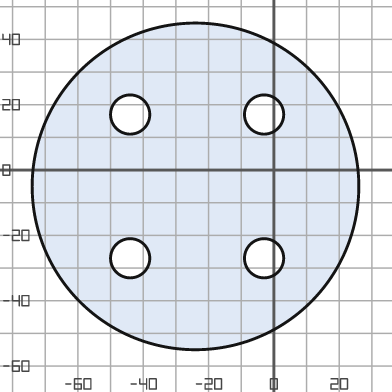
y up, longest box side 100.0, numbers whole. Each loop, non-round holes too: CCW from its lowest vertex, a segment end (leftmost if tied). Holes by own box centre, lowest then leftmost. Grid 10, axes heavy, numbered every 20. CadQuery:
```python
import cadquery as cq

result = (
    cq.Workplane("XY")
    .moveTo(-24.0, -5.0)
    .circle(50.0)
    .moveTo(-44.0, -27.0)
    .circle(6.0)
    .moveTo(-3.0, -27.0)
    .circle(6.0)
    .moveTo(-44.0, 17.0)
    .circle(6.0)
    .moveTo(-3.0, 17.0)
    .circle(6.0)
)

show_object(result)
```